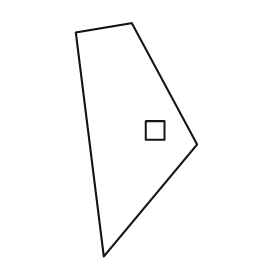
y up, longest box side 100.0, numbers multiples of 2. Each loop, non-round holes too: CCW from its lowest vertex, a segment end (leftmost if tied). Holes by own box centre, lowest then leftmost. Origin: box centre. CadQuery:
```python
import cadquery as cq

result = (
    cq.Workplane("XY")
    .moveTo(-14.0, -50.0)
    .lineTo(26.0, -2.0)
    .lineTo(-2.0, 50.0)
    .lineTo(-26.0, 46.0)
    .close()
    .moveTo(4.0, 0.0)
    .lineTo(12.0, 0.0)
    .lineTo(12.0, 8.0)
    .lineTo(4.0, 8.0)
    .close()
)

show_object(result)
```